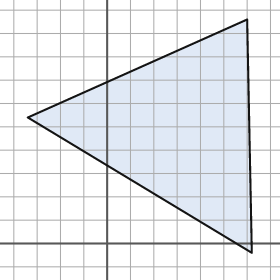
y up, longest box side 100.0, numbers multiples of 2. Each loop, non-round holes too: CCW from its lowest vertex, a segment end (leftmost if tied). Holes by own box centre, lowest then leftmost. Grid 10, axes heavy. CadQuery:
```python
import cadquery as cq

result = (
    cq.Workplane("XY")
    .moveTo(62.0, -4.0)
    .lineTo(60.0, 96.0)
    .lineTo(-34.0, 54.0)
    .close()
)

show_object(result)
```